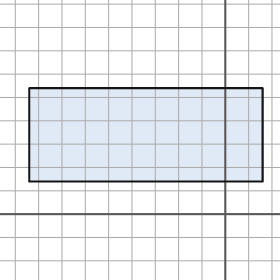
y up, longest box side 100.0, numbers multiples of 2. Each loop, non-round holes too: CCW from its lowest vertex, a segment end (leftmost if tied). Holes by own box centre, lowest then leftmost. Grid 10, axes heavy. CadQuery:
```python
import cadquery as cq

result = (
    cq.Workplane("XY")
    .moveTo(-84.0, 14.0)
    .lineTo(16.0, 14.0)
    .lineTo(16.0, 54.0)
    .lineTo(-84.0, 54.0)
    .close()
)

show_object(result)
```